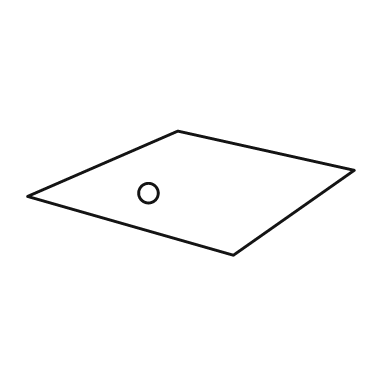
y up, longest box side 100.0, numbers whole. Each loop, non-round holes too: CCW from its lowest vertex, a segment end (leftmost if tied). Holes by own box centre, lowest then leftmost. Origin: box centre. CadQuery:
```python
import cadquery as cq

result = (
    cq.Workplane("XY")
    .moveTo(13.0, -19.0)
    .lineTo(50.0, 7.0)
    .lineTo(-4.0, 19.0)
    .lineTo(-50.0, -1.0)
    .close()
    .moveTo(-13.0, 0.0)
    .circle(3.0)
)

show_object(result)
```